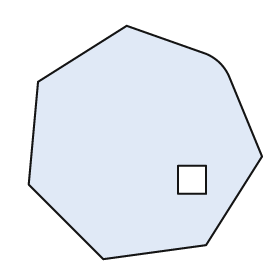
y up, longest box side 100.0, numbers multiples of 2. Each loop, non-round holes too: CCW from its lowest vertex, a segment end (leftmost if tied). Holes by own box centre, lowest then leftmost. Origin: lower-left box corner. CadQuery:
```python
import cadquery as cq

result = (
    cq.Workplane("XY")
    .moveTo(32.0, 0.0)
    .lineTo(76.0, 6.0)
    .lineTo(100.0, 44.0)
    .lineTo(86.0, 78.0)
    .threePointArc((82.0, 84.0), (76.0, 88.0))
    .lineTo(42.0, 100.0)
    .lineTo(4.0, 76.0)
    .lineTo(0.0, 32.0)
    .close()
    .moveTo(64.0, 28.0)
    .lineTo(76.0, 28.0)
    .lineTo(76.0, 40.0)
    .lineTo(64.0, 40.0)
    .close()
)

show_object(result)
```